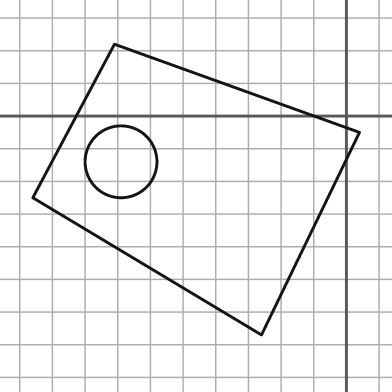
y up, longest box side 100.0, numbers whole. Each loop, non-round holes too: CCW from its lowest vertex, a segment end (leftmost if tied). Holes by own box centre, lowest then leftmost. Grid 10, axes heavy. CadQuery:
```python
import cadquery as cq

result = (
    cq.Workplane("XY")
    .moveTo(-26.0, -67.0)
    .lineTo(4.0, -5.0)
    .lineTo(-71.0, 22.0)
    .lineTo(-96.0, -25.0)
    .close()
    .moveTo(-69.0, -14.0)
    .circle(11.0)
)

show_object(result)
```